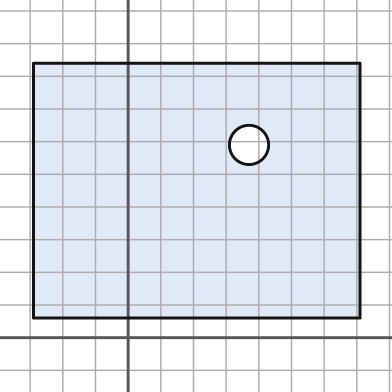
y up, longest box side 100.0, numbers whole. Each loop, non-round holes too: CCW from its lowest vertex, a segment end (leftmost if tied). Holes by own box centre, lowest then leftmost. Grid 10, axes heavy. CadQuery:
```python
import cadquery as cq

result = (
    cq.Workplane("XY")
    .moveTo(-29.0, 6.0)
    .lineTo(71.0, 6.0)
    .lineTo(71.0, 84.0)
    .lineTo(-29.0, 84.0)
    .close()
    .moveTo(37.0, 59.0)
    .circle(6.0)
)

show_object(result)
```